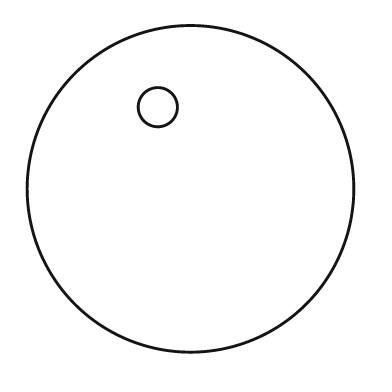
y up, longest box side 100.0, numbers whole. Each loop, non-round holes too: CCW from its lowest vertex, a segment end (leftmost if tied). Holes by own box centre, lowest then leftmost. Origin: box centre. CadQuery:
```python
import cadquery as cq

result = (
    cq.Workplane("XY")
    .moveTo(0.0, 0.0)
    .circle(50.0)
    .moveTo(-10.0, 25.0)
    .circle(6.0)
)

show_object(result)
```